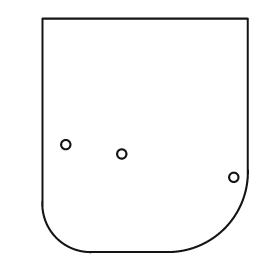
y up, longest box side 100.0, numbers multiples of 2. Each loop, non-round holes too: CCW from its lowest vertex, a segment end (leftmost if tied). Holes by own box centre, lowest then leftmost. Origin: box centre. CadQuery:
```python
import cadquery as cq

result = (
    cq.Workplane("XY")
    .moveTo(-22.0, -50.0)
    .lineTo(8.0, -50.0)
    .threePointArc((34.0, -40.0), (44.0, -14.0))
    .lineTo(44.0, 50.0)
    .lineTo(-44.0, 50.0)
    .lineTo(-44.0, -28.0)
    .threePointArc((-38.0, -44.0), (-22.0, -50.0))
    .close()
    .moveTo(38.0, -18.0)
    .circle(2.0)
    .moveTo(-10.0, -8.0)
    .circle(2.0)
    .moveTo(-34.0, -4.0)
    .circle(2.0)
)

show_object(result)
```